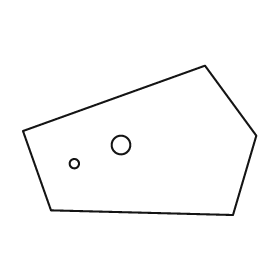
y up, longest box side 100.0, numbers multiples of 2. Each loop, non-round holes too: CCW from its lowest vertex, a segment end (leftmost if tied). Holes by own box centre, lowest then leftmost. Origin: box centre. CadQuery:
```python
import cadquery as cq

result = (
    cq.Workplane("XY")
    .moveTo(40.0, -32.0)
    .lineTo(50.0, 2.0)
    .lineTo(28.0, 32.0)
    .lineTo(-50.0, 4.0)
    .lineTo(-38.0, -30.0)
    .close()
    .moveTo(-28.0, -10.0)
    .circle(2.0)
    .moveTo(-8.0, -2.0)
    .circle(4.0)
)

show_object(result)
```